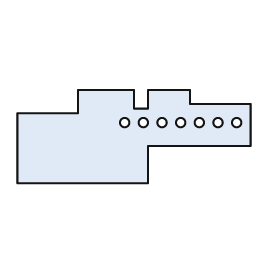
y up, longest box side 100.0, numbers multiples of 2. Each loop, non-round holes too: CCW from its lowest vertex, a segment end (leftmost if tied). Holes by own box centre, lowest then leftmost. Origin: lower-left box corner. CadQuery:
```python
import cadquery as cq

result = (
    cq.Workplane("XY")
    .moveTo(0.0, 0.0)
    .lineTo(56.0, 0.0)
    .lineTo(56.0, 16.0)
    .lineTo(100.0, 16.0)
    .lineTo(100.0, 34.0)
    .lineTo(74.0, 34.0)
    .lineTo(74.0, 40.0)
    .lineTo(56.0, 40.0)
    .lineTo(56.0, 32.0)
    .lineTo(50.0, 32.0)
    .lineTo(50.0, 40.0)
    .lineTo(26.0, 40.0)
    .lineTo(26.0, 30.0)
    .lineTo(0.0, 30.0)
    .close()
    .moveTo(46.0, 26.0)
    .circle(2.0)
    .moveTo(54.0, 26.0)
    .circle(2.0)
    .moveTo(62.0, 26.0)
    .circle(2.0)
    .moveTo(70.0, 26.0)
    .circle(2.0)
    .moveTo(78.0, 26.0)
    .circle(2.0)
    .moveTo(86.0, 26.0)
    .circle(2.0)
    .moveTo(94.0, 26.0)
    .circle(2.0)
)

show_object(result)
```